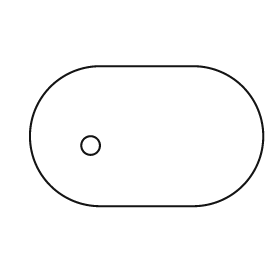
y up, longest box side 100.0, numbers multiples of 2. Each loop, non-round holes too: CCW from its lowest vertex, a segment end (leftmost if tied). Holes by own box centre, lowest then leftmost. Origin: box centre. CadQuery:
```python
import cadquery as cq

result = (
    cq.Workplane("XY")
    .moveTo(-20.0, -30.0)
    .lineTo(20.0, -30.0)
    .threePointArc((50.0, 0.0), (20.0, 30.0))
    .lineTo(-20.0, 30.0)
    .threePointArc((-50.0, 0.0), (-20.0, -30.0))
    .close()
    .moveTo(-24.0, -4.0)
    .circle(4.0)
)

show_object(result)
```